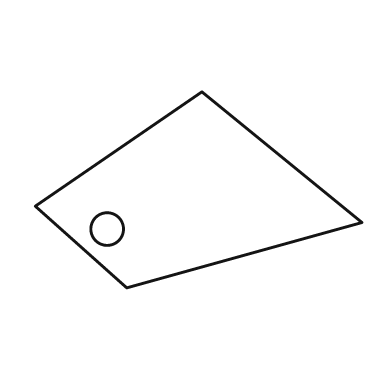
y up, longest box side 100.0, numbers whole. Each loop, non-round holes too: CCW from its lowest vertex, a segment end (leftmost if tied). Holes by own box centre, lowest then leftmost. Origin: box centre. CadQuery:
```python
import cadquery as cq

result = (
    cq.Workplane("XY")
    .moveTo(-22.0, -30.0)
    .lineTo(50.0, -10.0)
    .lineTo(1.0, 30.0)
    .lineTo(-50.0, -5.0)
    .close()
    .moveTo(-28.0, -12.0)
    .circle(5.0)
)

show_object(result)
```